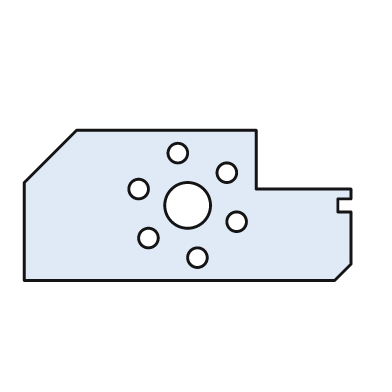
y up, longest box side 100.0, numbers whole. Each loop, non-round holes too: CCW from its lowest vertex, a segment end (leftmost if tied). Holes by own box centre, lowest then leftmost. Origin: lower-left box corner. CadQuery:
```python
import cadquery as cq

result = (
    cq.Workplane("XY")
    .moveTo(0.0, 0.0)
    .lineTo(95.0, 0.0)
    .lineTo(100.0, 5.0)
    .lineTo(100.0, 21.0)
    .lineTo(96.0, 21.0)
    .lineTo(96.0, 25.0)
    .lineTo(100.0, 25.0)
    .lineTo(100.0, 28.0)
    .lineTo(71.0, 28.0)
    .lineTo(71.0, 46.0)
    .lineTo(16.0, 46.0)
    .lineTo(0.0, 30.0)
    .close()
    .moveTo(53.0, 7.0)
    .circle(3.0)
    .moveTo(38.0, 13.0)
    .circle(3.0)
    .moveTo(65.0, 18.0)
    .circle(3.0)
    .moveTo(50.0, 23.0)
    .circle(7.0)
    .moveTo(35.0, 28.0)
    .circle(3.0)
    .moveTo(62.0, 33.0)
    .circle(3.0)
    .moveTo(47.0, 39.0)
    .circle(3.0)
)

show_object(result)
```